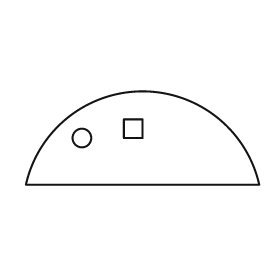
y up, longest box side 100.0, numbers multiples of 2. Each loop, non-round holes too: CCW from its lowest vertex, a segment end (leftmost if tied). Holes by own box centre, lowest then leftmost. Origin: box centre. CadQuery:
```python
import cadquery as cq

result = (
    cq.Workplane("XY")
    .moveTo(-50.0, -20.0)
    .lineTo(50.0, -20.0)
    .threePointArc((0.0, 20.0), (-50.0, -20.0))
    .close()
    .moveTo(-26.0, 0.0)
    .circle(4.0)
    .moveTo(-8.0, 0.0)
    .lineTo(0.0, 0.0)
    .lineTo(0.0, 8.0)
    .lineTo(-8.0, 8.0)
    .close()
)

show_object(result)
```